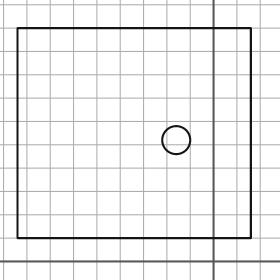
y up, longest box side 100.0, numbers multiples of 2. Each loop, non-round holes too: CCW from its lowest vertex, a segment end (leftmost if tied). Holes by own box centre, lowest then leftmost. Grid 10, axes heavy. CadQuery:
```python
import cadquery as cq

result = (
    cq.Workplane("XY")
    .moveTo(-84.0, 10.0)
    .lineTo(16.0, 10.0)
    .lineTo(16.0, 100.0)
    .lineTo(-84.0, 100.0)
    .close()
    .moveTo(-16.0, 52.0)
    .circle(6.0)
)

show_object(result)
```